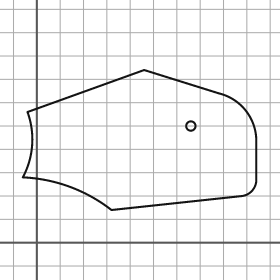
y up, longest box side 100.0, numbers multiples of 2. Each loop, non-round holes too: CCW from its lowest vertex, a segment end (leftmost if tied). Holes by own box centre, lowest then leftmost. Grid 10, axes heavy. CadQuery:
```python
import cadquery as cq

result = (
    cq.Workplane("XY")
    .moveTo(32.0, 14.0)
    .lineTo(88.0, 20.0)
    .threePointArc((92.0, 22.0), (94.0, 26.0))
    .lineTo(94.0, 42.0)
    .threePointArc((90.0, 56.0), (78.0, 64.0))
    .lineTo(46.0, 74.0)
    .lineTo(-4.0, 56.0)
    .threePointArc((-2.0, 42.0), (-6.0, 28.0))
    .threePointArc((14.0, 24.0), (32.0, 14.0))
    .close()
    .moveTo(66.0, 50.0)
    .circle(2.0)
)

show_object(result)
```